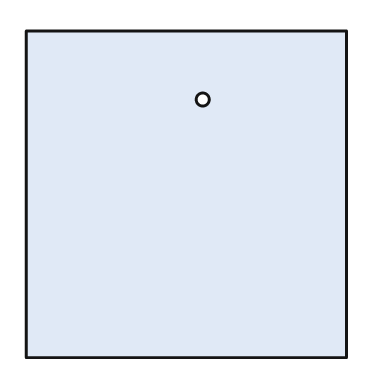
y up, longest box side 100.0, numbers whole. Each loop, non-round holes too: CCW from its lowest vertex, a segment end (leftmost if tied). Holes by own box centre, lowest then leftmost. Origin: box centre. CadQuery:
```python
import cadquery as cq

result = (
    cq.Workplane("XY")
    .moveTo(-49.0, -50.0)
    .lineTo(49.0, -50.0)
    .lineTo(49.0, 50.0)
    .lineTo(-49.0, 50.0)
    .close()
    .moveTo(5.0, 29.0)
    .circle(2.0)
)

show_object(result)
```